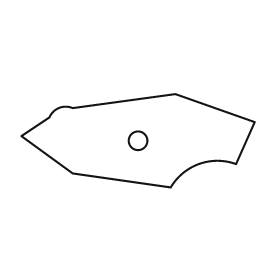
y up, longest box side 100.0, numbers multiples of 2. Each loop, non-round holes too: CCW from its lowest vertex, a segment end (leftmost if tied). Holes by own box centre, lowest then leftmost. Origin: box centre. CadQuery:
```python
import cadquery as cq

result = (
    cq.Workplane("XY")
    .moveTo(14.0, -20.0)
    .threePointArc((26.0, -10.0), (42.0, -10.0))
    .lineTo(50.0, 8.0)
    .lineTo(16.0, 20.0)
    .lineTo(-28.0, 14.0)
    .threePointArc((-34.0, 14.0), (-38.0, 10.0))
    .lineTo(-50.0, 2.0)
    .lineTo(-28.0, -14.0)
    .close()
    .moveTo(0.0, 0.0)
    .circle(4.0)
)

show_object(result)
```